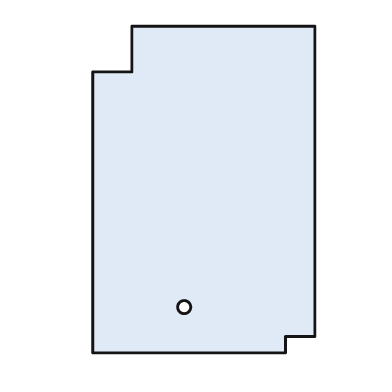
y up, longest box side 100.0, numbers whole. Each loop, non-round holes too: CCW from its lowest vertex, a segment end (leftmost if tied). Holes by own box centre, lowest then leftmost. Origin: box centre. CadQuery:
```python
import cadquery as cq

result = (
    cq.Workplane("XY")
    .moveTo(-34.0, -50.0)
    .lineTo(25.0, -50.0)
    .lineTo(25.0, -45.0)
    .lineTo(34.0, -45.0)
    .lineTo(34.0, 50.0)
    .lineTo(-22.0, 50.0)
    .lineTo(-22.0, 36.0)
    .lineTo(-34.0, 36.0)
    .close()
    .moveTo(-6.0, -36.0)
    .circle(2.0)
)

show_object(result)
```